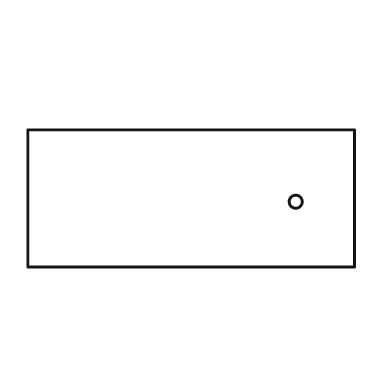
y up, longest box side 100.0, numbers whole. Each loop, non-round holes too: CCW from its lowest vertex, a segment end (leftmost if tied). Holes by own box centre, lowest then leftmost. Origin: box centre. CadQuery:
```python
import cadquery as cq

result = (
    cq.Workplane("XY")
    .moveTo(-50.0, -21.0)
    .lineTo(50.0, -21.0)
    .lineTo(50.0, 21.0)
    .lineTo(-50.0, 21.0)
    .close()
    .moveTo(32.0, -1.0)
    .circle(2.0)
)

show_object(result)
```